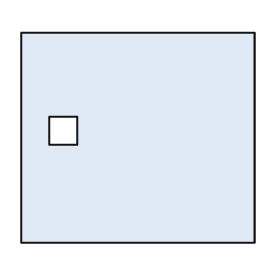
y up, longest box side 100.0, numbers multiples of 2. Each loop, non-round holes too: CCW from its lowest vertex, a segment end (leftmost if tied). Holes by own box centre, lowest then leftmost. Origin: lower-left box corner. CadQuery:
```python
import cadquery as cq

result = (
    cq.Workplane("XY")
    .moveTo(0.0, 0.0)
    .lineTo(100.0, 0.0)
    .lineTo(100.0, 90.0)
    .lineTo(0.0, 90.0)
    .close()
    .moveTo(12.0, 42.0)
    .lineTo(24.0, 42.0)
    .lineTo(24.0, 54.0)
    .lineTo(12.0, 54.0)
    .close()
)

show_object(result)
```